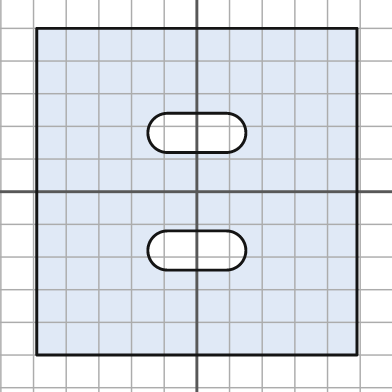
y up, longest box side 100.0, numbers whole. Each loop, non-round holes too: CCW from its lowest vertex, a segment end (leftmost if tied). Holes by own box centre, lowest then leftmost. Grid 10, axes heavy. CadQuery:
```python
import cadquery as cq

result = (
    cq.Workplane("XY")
    .moveTo(-49.0, -50.0)
    .lineTo(49.0, -50.0)
    .lineTo(49.0, 50.0)
    .lineTo(-49.0, 50.0)
    .close()
    .moveTo(-9.0, -24.0)
    .lineTo(9.0, -24.0)
    .threePointArc((15.0, -18.0), (9.0, -12.0))
    .lineTo(-9.0, -12.0)
    .threePointArc((-15.0, -18.0), (-9.0, -24.0))
    .close()
    .moveTo(-9.0, 12.0)
    .lineTo(9.0, 12.0)
    .threePointArc((15.0, 18.0), (9.0, 24.0))
    .lineTo(-9.0, 24.0)
    .threePointArc((-15.0, 18.0), (-9.0, 12.0))
    .close()
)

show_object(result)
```